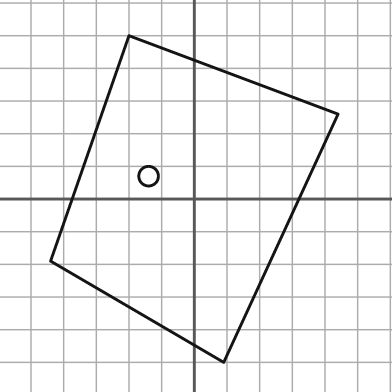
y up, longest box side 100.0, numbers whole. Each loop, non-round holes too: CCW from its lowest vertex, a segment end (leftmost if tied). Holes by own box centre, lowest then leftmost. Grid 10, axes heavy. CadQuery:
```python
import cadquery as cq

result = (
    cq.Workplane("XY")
    .moveTo(9.0, -50.0)
    .lineTo(44.0, 26.0)
    .lineTo(-20.0, 50.0)
    .lineTo(-44.0, -19.0)
    .close()
    .moveTo(-14.0, 7.0)
    .circle(3.0)
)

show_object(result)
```